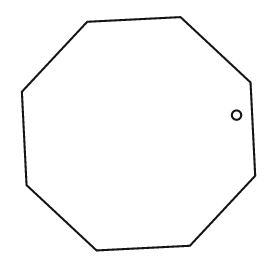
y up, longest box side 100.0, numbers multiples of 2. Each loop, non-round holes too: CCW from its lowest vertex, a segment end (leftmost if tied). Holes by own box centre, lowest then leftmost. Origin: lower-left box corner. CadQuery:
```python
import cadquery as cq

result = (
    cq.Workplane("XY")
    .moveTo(32.0, 0.0)
    .lineTo(72.0, 2.0)
    .lineTo(100.0, 32.0)
    .lineTo(98.0, 72.0)
    .lineTo(68.0, 100.0)
    .lineTo(28.0, 98.0)
    .lineTo(0.0, 68.0)
    .lineTo(2.0, 28.0)
    .close()
    .moveTo(92.0, 58.0)
    .circle(2.0)
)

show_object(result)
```